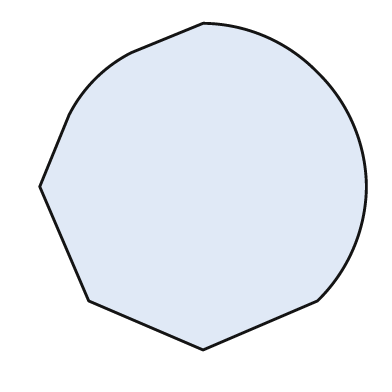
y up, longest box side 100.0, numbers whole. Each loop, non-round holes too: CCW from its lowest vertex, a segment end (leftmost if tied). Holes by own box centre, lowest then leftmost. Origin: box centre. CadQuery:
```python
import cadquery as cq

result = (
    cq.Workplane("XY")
    .moveTo(0.0, -50.0)
    .lineTo(35.0, -35.0)
    .threePointArc((46.0, -19.0), (50.0, 0.0))
    .threePointArc((46.0, 19.0), (35.0, 35.0))
    .threePointArc((19.0, 46.0), (0.0, 50.0))
    .lineTo(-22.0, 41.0)
    .threePointArc((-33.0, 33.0), (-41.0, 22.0))
    .lineTo(-50.0, 0.0)
    .lineTo(-35.0, -35.0)
    .close()
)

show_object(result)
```